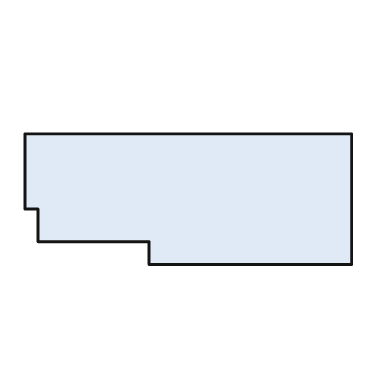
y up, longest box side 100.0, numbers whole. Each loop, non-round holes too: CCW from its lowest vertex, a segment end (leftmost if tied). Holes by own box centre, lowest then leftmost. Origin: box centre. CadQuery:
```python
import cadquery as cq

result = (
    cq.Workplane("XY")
    .moveTo(-12.0, -20.0)
    .lineTo(50.0, -20.0)
    .lineTo(50.0, 20.0)
    .lineTo(-50.0, 20.0)
    .lineTo(-50.0, -3.0)
    .lineTo(-46.0, -3.0)
    .lineTo(-46.0, -13.0)
    .lineTo(-12.0, -13.0)
    .close()
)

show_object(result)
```